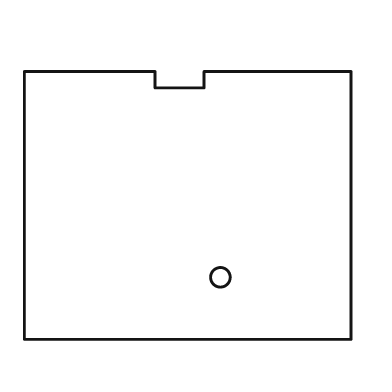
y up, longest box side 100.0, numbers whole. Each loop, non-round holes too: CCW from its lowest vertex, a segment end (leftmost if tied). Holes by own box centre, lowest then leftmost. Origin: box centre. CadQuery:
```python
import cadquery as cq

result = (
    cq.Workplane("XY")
    .moveTo(-50.0, -41.0)
    .lineTo(50.0, -41.0)
    .lineTo(50.0, 41.0)
    .lineTo(5.0, 41.0)
    .lineTo(5.0, 36.0)
    .lineTo(-10.0, 36.0)
    .lineTo(-10.0, 41.0)
    .lineTo(-50.0, 41.0)
    .close()
    .moveTo(10.0, -22.0)
    .circle(3.0)
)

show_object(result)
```